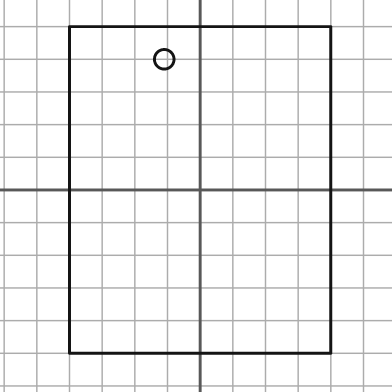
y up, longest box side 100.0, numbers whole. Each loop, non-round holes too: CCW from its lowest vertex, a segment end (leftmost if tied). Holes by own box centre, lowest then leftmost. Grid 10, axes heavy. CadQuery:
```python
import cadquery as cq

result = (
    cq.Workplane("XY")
    .moveTo(-40.0, -50.0)
    .lineTo(40.0, -50.0)
    .lineTo(40.0, 50.0)
    .lineTo(-40.0, 50.0)
    .close()
    .moveTo(-11.0, 40.0)
    .circle(3.0)
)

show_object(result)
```